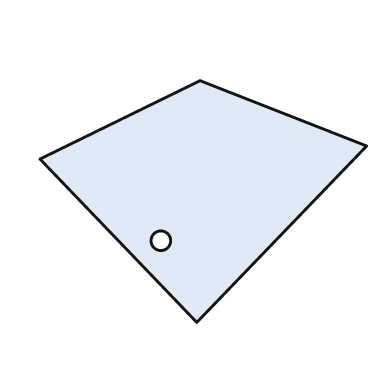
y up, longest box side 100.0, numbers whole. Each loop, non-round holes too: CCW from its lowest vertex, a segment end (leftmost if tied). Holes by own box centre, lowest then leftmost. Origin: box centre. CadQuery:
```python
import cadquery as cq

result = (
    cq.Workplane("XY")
    .moveTo(-2.0, -37.0)
    .lineTo(50.0, 17.0)
    .lineTo(-1.0, 37.0)
    .lineTo(-50.0, 13.0)
    .close()
    .moveTo(-13.0, -12.0)
    .circle(3.0)
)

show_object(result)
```